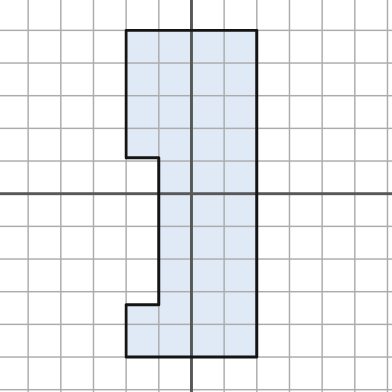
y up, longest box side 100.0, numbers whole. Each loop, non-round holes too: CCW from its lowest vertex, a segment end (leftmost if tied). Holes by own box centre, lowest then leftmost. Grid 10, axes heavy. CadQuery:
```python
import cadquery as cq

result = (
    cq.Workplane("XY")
    .moveTo(-20.0, -50.0)
    .lineTo(20.0, -50.0)
    .lineTo(20.0, 50.0)
    .lineTo(-20.0, 50.0)
    .lineTo(-20.0, 11.0)
    .lineTo(-10.0, 11.0)
    .lineTo(-10.0, -34.0)
    .lineTo(-20.0, -34.0)
    .close()
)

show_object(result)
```